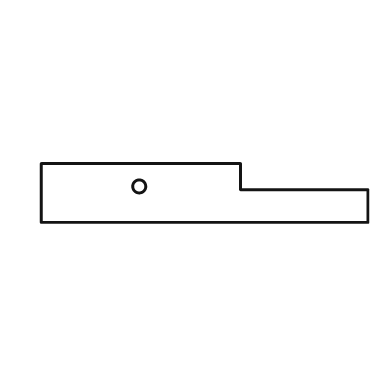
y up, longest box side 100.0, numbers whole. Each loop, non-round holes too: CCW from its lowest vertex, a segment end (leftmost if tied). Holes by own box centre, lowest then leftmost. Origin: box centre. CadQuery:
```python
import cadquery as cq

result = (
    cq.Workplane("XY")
    .moveTo(-50.0, -9.0)
    .lineTo(50.0, -9.0)
    .lineTo(50.0, 1.0)
    .lineTo(11.0, 1.0)
    .lineTo(11.0, 9.0)
    .lineTo(-50.0, 9.0)
    .close()
    .moveTo(-20.0, 2.0)
    .circle(2.0)
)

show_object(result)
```